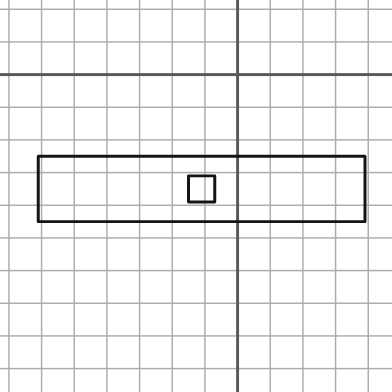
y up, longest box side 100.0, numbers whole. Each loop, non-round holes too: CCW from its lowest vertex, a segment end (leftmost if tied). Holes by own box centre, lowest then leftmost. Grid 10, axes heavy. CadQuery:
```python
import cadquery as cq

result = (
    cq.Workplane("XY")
    .moveTo(-61.0, -45.0)
    .lineTo(39.0, -45.0)
    .lineTo(39.0, -25.0)
    .lineTo(-61.0, -25.0)
    .close()
    .moveTo(-15.0, -39.0)
    .lineTo(-7.0, -39.0)
    .lineTo(-7.0, -31.0)
    .lineTo(-15.0, -31.0)
    .close()
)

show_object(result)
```